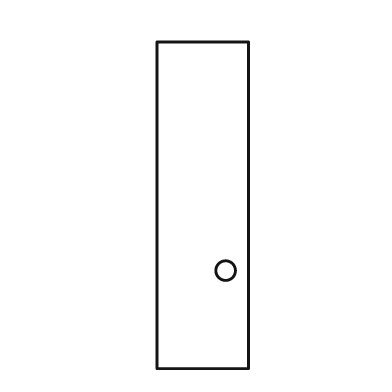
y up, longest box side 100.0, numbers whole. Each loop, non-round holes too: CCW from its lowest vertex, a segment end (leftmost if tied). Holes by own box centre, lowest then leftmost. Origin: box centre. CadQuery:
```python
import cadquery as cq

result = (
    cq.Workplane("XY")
    .moveTo(-14.0, -50.0)
    .lineTo(14.0, -50.0)
    .lineTo(14.0, 50.0)
    .lineTo(-14.0, 50.0)
    .close()
    .moveTo(7.0, -20.0)
    .circle(3.0)
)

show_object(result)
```